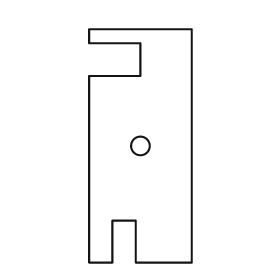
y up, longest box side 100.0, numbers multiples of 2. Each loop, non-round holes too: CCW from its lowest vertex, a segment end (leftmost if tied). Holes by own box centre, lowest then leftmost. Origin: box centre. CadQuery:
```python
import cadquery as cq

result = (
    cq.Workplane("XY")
    .moveTo(-22.0, -50.0)
    .lineTo(-12.0, -50.0)
    .lineTo(-12.0, -32.0)
    .lineTo(-2.0, -32.0)
    .lineTo(-2.0, -50.0)
    .lineTo(22.0, -50.0)
    .lineTo(22.0, 50.0)
    .lineTo(-22.0, 50.0)
    .lineTo(-22.0, 44.0)
    .lineTo(0.0, 44.0)
    .lineTo(0.0, 30.0)
    .lineTo(-22.0, 30.0)
    .close()
    .moveTo(0.0, 0.0)
    .circle(4.0)
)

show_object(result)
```